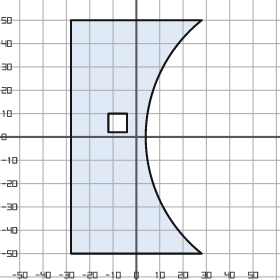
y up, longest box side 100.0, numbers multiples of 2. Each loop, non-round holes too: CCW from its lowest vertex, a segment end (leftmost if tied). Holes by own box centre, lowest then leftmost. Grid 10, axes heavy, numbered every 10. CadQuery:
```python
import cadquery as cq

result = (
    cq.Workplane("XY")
    .moveTo(-28.0, -50.0)
    .lineTo(28.0, -50.0)
    .threePointArc((4.0, 0.0), (28.0, 50.0))
    .lineTo(-28.0, 50.0)
    .close()
    .moveTo(-12.0, 2.0)
    .lineTo(-4.0, 2.0)
    .lineTo(-4.0, 10.0)
    .lineTo(-12.0, 10.0)
    .close()
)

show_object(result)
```